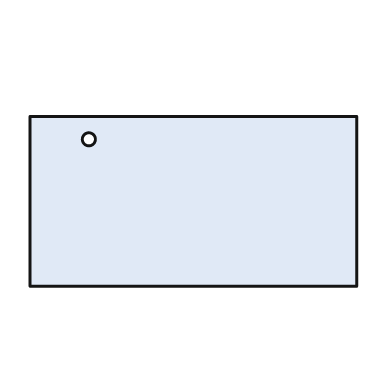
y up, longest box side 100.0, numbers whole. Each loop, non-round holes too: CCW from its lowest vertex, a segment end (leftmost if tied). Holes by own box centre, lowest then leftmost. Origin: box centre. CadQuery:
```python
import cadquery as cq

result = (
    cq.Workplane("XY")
    .moveTo(-50.0, -26.0)
    .lineTo(50.0, -26.0)
    .lineTo(50.0, 26.0)
    .lineTo(-50.0, 26.0)
    .close()
    .moveTo(-32.0, 19.0)
    .circle(2.0)
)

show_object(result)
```